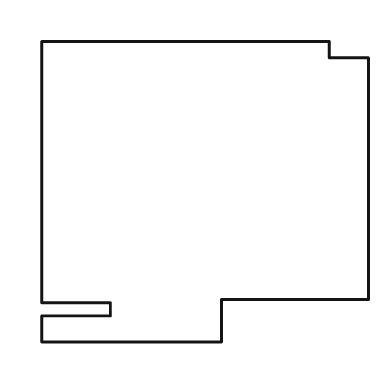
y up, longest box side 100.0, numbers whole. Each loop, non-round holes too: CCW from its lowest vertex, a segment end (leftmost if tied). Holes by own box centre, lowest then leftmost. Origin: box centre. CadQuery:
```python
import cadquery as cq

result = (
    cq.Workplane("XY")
    .moveTo(-50.0, -46.0)
    .lineTo(5.0, -46.0)
    .lineTo(5.0, -33.0)
    .lineTo(50.0, -33.0)
    .lineTo(50.0, 41.0)
    .lineTo(38.0, 41.0)
    .lineTo(38.0, 46.0)
    .lineTo(-50.0, 46.0)
    .lineTo(-50.0, -34.0)
    .lineTo(-29.0, -34.0)
    .lineTo(-29.0, -38.0)
    .lineTo(-50.0, -38.0)
    .close()
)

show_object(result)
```